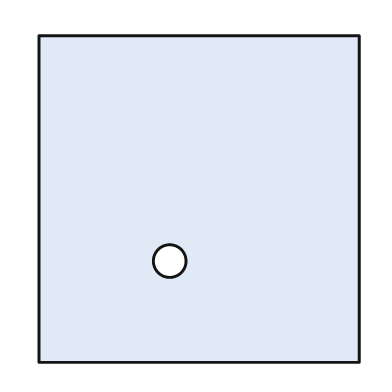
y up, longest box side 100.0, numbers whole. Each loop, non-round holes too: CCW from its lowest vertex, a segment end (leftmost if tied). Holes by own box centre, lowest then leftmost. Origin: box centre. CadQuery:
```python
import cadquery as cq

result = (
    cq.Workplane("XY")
    .moveTo(-49.0, -50.0)
    .lineTo(49.0, -50.0)
    .lineTo(49.0, 50.0)
    .lineTo(-49.0, 50.0)
    .close()
    .moveTo(-9.0, -19.0)
    .circle(5.0)
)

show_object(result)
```